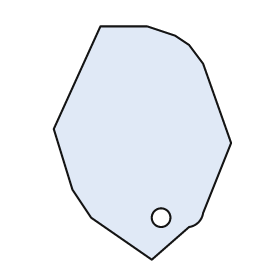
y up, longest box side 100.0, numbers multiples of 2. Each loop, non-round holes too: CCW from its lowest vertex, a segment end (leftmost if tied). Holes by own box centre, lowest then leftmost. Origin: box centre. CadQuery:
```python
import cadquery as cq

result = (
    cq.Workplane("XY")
    .moveTo(4.0, -50.0)
    .lineTo(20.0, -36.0)
    .threePointArc((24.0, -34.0), (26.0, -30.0))
    .lineTo(38.0, 0.0)
    .lineTo(26.0, 34.0)
    .lineTo(20.0, 42.0)
    .lineTo(14.0, 46.0)
    .lineTo(2.0, 50.0)
    .lineTo(-18.0, 50.0)
    .lineTo(-38.0, 6.0)
    .lineTo(-30.0, -20.0)
    .lineTo(-22.0, -32.0)
    .close()
    .moveTo(8.0, -32.0)
    .circle(4.0)
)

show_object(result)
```